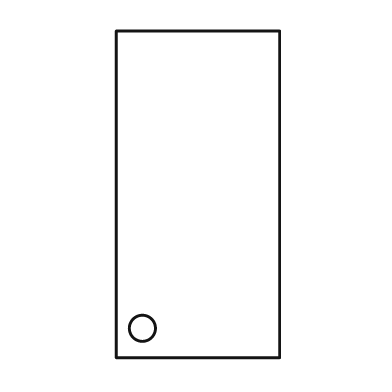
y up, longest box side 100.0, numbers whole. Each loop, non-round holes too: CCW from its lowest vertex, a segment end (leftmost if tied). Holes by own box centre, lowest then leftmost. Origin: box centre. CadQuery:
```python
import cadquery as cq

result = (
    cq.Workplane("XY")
    .moveTo(-25.0, -50.0)
    .lineTo(25.0, -50.0)
    .lineTo(25.0, 50.0)
    .lineTo(-25.0, 50.0)
    .close()
    .moveTo(-17.0, -41.0)
    .circle(4.0)
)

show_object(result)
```